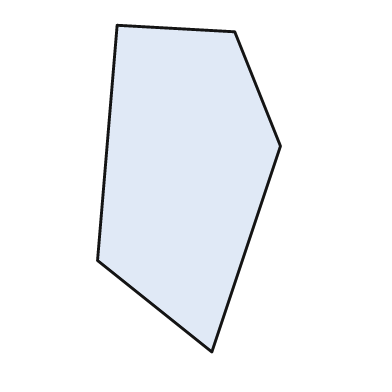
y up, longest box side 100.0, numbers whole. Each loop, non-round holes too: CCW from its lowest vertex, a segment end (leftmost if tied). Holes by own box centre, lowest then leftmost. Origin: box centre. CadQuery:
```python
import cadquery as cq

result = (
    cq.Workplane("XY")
    .moveTo(7.0, -50.0)
    .lineTo(28.0, 13.0)
    .lineTo(14.0, 48.0)
    .lineTo(-22.0, 50.0)
    .lineTo(-28.0, -22.0)
    .close()
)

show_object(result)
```